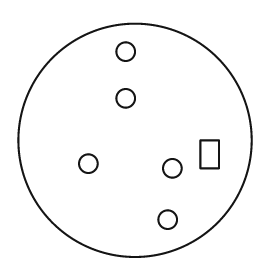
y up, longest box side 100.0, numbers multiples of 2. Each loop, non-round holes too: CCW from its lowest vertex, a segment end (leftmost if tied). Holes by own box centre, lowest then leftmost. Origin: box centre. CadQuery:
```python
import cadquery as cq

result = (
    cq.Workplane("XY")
    .moveTo(0.0, 0.0)
    .circle(50.0)
    .moveTo(14.0, -34.0)
    .circle(4.0)
    .moveTo(16.0, -12.0)
    .circle(4.0)
    .moveTo(-20.0, -10.0)
    .circle(4.0)
    .moveTo(28.0, -12.0)
    .lineTo(36.0, -12.0)
    .lineTo(36.0, 0.0)
    .lineTo(28.0, 0.0)
    .close()
    .moveTo(-4.0, 18.0)
    .circle(4.0)
    .moveTo(-4.0, 38.0)
    .circle(4.0)
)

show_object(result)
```